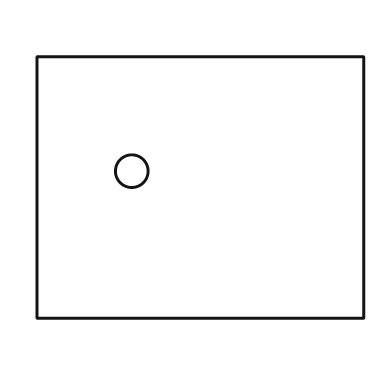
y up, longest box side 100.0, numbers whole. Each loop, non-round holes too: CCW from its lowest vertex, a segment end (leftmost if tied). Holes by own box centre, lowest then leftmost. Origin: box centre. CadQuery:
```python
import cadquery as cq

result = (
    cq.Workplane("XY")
    .moveTo(-50.0, -40.0)
    .lineTo(50.0, -40.0)
    .lineTo(50.0, 40.0)
    .lineTo(-50.0, 40.0)
    .close()
    .moveTo(-21.0, 5.0)
    .circle(5.0)
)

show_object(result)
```